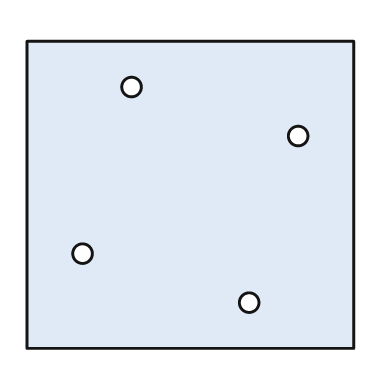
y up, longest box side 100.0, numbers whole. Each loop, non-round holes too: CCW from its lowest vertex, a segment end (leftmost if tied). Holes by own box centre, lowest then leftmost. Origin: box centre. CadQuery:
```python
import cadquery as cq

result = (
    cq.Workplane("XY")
    .moveTo(-50.0, -47.0)
    .lineTo(50.0, -47.0)
    .lineTo(50.0, 47.0)
    .lineTo(-50.0, 47.0)
    .close()
    .moveTo(18.0, -33.0)
    .circle(3.0)
    .moveTo(-33.0, -18.0)
    .circle(3.0)
    .moveTo(33.0, 18.0)
    .circle(3.0)
    .moveTo(-18.0, 33.0)
    .circle(3.0)
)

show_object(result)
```